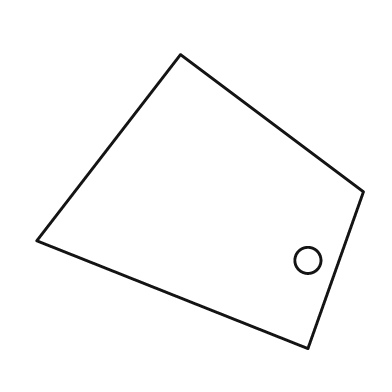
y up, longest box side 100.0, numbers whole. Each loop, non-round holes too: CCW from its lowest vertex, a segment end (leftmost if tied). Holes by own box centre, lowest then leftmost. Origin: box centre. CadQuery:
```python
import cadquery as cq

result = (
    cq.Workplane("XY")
    .moveTo(33.0, -45.0)
    .lineTo(50.0, 3.0)
    .lineTo(-6.0, 45.0)
    .lineTo(-50.0, -12.0)
    .close()
    .moveTo(33.0, -18.0)
    .circle(4.0)
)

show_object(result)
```